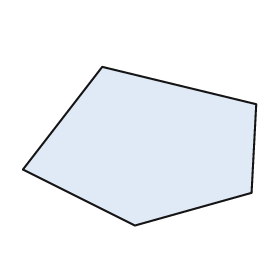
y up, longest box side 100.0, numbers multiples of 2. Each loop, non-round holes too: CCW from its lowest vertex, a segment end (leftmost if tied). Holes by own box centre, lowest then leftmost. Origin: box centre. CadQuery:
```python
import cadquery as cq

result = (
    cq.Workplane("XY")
    .moveTo(-2.0, -34.0)
    .lineTo(48.0, -20.0)
    .lineTo(50.0, 18.0)
    .lineTo(-16.0, 34.0)
    .lineTo(-50.0, -10.0)
    .close()
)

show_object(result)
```